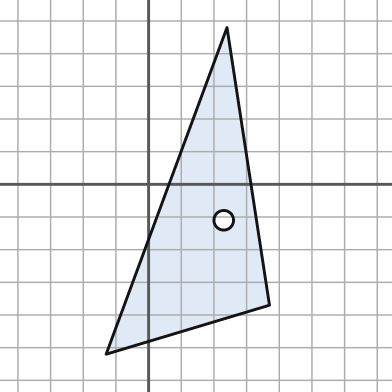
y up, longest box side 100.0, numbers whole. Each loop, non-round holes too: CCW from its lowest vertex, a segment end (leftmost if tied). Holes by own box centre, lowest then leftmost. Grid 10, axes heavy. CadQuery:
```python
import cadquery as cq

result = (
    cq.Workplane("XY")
    .moveTo(-13.0, -52.0)
    .lineTo(37.0, -37.0)
    .lineTo(24.0, 48.0)
    .close()
    .moveTo(23.0, -11.0)
    .circle(3.0)
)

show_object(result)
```